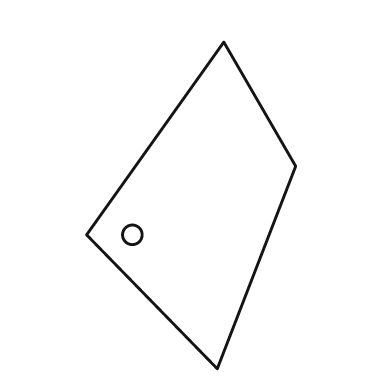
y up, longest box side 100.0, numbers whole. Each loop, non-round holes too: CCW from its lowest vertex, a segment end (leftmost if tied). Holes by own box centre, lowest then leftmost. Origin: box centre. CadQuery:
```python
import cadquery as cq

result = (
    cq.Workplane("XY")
    .moveTo(8.0, -50.0)
    .lineTo(32.0, 12.0)
    .lineTo(10.0, 50.0)
    .lineTo(-32.0, -9.0)
    .close()
    .moveTo(-18.0, -9.0)
    .circle(3.0)
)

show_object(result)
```